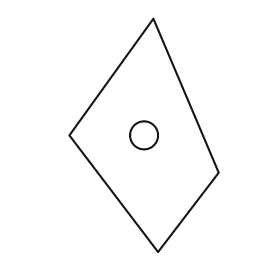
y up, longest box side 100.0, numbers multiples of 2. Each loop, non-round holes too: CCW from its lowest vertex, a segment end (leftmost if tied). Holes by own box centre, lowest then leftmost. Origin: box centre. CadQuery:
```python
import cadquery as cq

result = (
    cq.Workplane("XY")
    .moveTo(6.0, -50.0)
    .lineTo(32.0, -16.0)
    .lineTo(4.0, 50.0)
    .lineTo(-32.0, 0.0)
    .close()
    .moveTo(0.0, 0.0)
    .circle(6.0)
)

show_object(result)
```